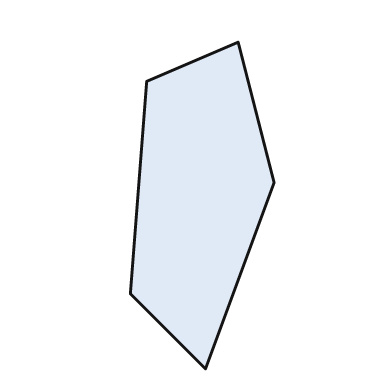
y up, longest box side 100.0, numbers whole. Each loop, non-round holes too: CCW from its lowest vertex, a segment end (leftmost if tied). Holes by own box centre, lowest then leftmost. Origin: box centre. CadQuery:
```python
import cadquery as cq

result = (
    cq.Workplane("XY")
    .moveTo(1.0, -50.0)
    .lineTo(22.0, 7.0)
    .lineTo(11.0, 50.0)
    .lineTo(-17.0, 38.0)
    .lineTo(-22.0, -27.0)
    .close()
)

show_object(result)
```